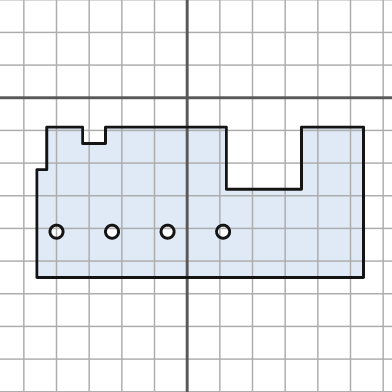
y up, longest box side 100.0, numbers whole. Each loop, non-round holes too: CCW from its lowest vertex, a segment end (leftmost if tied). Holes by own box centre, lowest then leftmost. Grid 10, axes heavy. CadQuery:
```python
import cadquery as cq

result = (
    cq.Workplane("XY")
    .moveTo(-46.0, -55.0)
    .lineTo(54.0, -55.0)
    .lineTo(54.0, -9.0)
    .lineTo(35.0, -9.0)
    .lineTo(35.0, -28.0)
    .lineTo(12.0, -28.0)
    .lineTo(12.0, -9.0)
    .lineTo(-25.0, -9.0)
    .lineTo(-25.0, -14.0)
    .lineTo(-32.0, -14.0)
    .lineTo(-32.0, -9.0)
    .lineTo(-43.0, -9.0)
    .lineTo(-43.0, -22.0)
    .lineTo(-46.0, -22.0)
    .close()
    .moveTo(-40.0, -41.0)
    .circle(2.0)
    .moveTo(-23.0, -41.0)
    .circle(2.0)
    .moveTo(-6.0, -41.0)
    .circle(2.0)
    .moveTo(11.0, -41.0)
    .circle(2.0)
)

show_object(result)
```